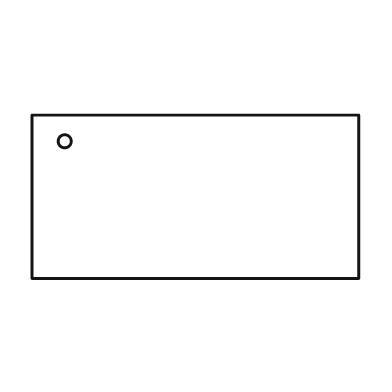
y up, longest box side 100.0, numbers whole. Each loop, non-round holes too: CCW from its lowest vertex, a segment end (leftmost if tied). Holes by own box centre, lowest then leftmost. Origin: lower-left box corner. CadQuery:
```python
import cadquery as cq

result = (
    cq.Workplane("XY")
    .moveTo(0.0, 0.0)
    .lineTo(100.0, 0.0)
    .lineTo(100.0, 50.0)
    .lineTo(0.0, 50.0)
    .close()
    .moveTo(10.0, 42.0)
    .circle(2.0)
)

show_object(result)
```